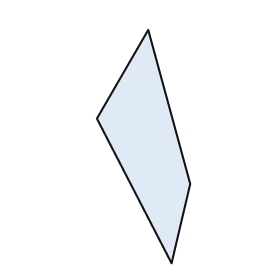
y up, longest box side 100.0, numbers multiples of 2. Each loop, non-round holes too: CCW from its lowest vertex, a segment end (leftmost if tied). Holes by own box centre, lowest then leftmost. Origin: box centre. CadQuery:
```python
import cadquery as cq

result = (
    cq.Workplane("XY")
    .moveTo(12.0, -50.0)
    .lineTo(20.0, -16.0)
    .lineTo(2.0, 50.0)
    .lineTo(-20.0, 12.0)
    .close()
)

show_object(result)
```